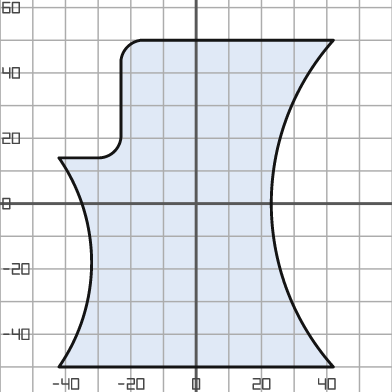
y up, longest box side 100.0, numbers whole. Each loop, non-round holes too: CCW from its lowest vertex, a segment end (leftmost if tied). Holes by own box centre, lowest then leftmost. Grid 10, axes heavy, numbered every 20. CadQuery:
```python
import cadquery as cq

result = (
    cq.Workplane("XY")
    .moveTo(-42.0, -50.0)
    .lineTo(42.0, -50.0)
    .threePointArc((23.0, 0.0), (42.0, 50.0))
    .lineTo(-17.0, 50.0)
    .threePointArc((-21.0, 48.0), (-23.0, 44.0))
    .lineTo(-23.0, 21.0)
    .threePointArc((-25.0, 16.0), (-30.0, 14.0))
    .lineTo(-42.0, 14.0)
    .threePointArc((-32.0, -18.0), (-42.0, -50.0))
    .close()
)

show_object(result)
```